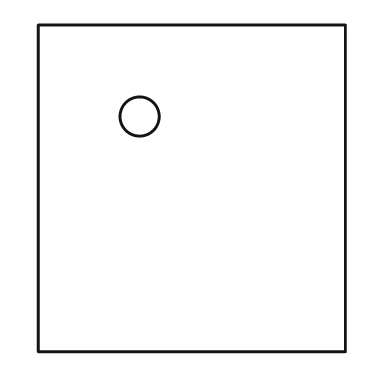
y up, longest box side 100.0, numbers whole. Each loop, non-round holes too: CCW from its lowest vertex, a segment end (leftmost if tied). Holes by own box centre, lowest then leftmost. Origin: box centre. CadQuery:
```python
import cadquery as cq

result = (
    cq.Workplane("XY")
    .moveTo(-47.0, -50.0)
    .lineTo(47.0, -50.0)
    .lineTo(47.0, 50.0)
    .lineTo(-47.0, 50.0)
    .close()
    .moveTo(-16.0, 22.0)
    .circle(6.0)
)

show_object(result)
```